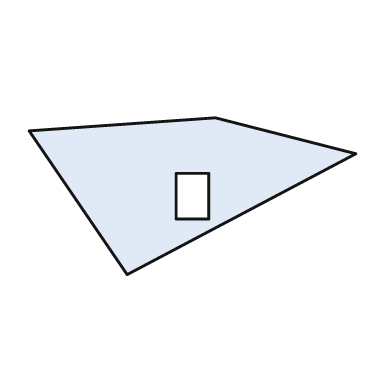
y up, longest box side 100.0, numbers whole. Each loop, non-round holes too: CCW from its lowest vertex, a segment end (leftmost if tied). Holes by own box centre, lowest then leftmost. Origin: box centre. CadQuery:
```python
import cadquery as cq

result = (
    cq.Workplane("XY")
    .moveTo(-20.0, -24.0)
    .lineTo(50.0, 13.0)
    .lineTo(7.0, 24.0)
    .lineTo(-50.0, 20.0)
    .close()
    .moveTo(-5.0, -7.0)
    .lineTo(5.0, -7.0)
    .lineTo(5.0, 7.0)
    .lineTo(-5.0, 7.0)
    .close()
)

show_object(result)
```